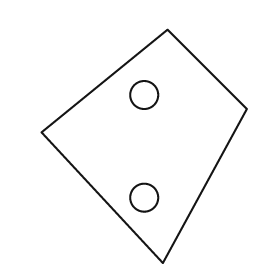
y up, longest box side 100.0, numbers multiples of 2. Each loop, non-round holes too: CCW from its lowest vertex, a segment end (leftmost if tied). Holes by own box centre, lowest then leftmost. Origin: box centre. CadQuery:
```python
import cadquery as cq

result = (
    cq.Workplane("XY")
    .moveTo(8.0, -50.0)
    .lineTo(44.0, 16.0)
    .lineTo(10.0, 50.0)
    .lineTo(-44.0, 6.0)
    .close()
    .moveTo(0.0, -22.0)
    .circle(6.0)
    .moveTo(0.0, 22.0)
    .circle(6.0)
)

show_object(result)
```